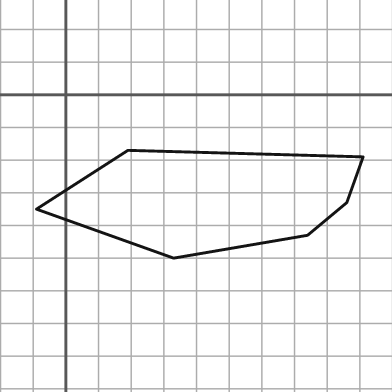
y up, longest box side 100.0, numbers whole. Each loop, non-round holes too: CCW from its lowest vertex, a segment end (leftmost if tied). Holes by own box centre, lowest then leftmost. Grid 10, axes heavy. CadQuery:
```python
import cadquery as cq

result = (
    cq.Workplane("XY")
    .moveTo(33.0, -50.0)
    .lineTo(74.0, -43.0)
    .lineTo(86.0, -33.0)
    .lineTo(91.0, -19.0)
    .lineTo(19.0, -17.0)
    .lineTo(-9.0, -35.0)
    .close()
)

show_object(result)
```